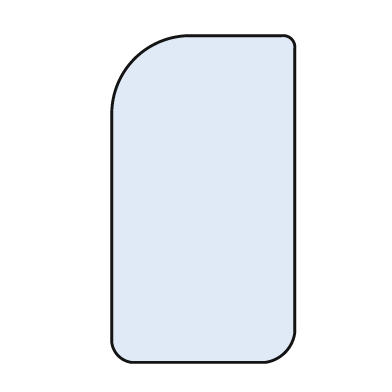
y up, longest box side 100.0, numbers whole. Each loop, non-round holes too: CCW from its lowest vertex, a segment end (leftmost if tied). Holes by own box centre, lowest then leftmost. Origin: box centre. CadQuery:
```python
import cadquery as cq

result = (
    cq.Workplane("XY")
    .moveTo(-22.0, -50.0)
    .lineTo(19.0, -50.0)
    .threePointArc((25.0, -47.0), (28.0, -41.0))
    .lineTo(28.0, 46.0)
    .threePointArc((27.0, 49.0), (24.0, 50.0))
    .lineTo(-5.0, 50.0)
    .threePointArc((-21.0, 43.0), (-28.0, 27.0))
    .lineTo(-28.0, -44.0)
    .threePointArc((-26.0, -48.0), (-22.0, -50.0))
    .close()
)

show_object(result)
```